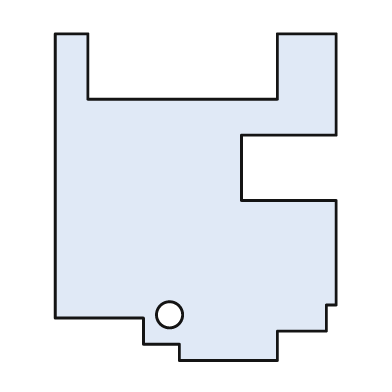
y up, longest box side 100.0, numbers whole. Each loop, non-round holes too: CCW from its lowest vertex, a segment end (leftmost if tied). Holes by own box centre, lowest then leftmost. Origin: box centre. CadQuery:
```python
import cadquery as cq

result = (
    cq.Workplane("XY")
    .moveTo(-5.0, -50.0)
    .lineTo(25.0, -50.0)
    .lineTo(25.0, -41.0)
    .lineTo(40.0, -41.0)
    .lineTo(40.0, -33.0)
    .lineTo(43.0, -33.0)
    .lineTo(43.0, -1.0)
    .lineTo(14.0, -1.0)
    .lineTo(14.0, 19.0)
    .lineTo(43.0, 19.0)
    .lineTo(43.0, 50.0)
    .lineTo(25.0, 50.0)
    .lineTo(25.0, 30.0)
    .lineTo(-33.0, 30.0)
    .lineTo(-33.0, 50.0)
    .lineTo(-43.0, 50.0)
    .lineTo(-43.0, -37.0)
    .lineTo(-16.0, -37.0)
    .lineTo(-16.0, -45.0)
    .lineTo(-5.0, -45.0)
    .close()
    .moveTo(-8.0, -36.0)
    .circle(4.0)
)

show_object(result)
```